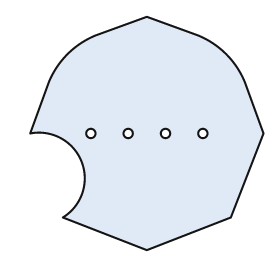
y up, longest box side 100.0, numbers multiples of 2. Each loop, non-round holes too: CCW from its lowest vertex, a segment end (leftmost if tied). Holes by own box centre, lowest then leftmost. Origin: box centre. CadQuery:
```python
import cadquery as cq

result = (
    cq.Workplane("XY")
    .moveTo(0.0, -50.0)
    .lineTo(36.0, -36.0)
    .lineTo(50.0, 0.0)
    .lineTo(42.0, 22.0)
    .threePointArc((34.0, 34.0), (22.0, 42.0))
    .lineTo(0.0, 50.0)
    .lineTo(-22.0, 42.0)
    .threePointArc((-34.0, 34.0), (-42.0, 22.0))
    .lineTo(-50.0, 0.0)
    .threePointArc((-28.0, -12.0), (-36.0, -36.0))
    .close()
    .moveTo(-24.0, 0.0)
    .circle(2.0)
    .moveTo(-8.0, 0.0)
    .circle(2.0)
    .moveTo(8.0, 0.0)
    .circle(2.0)
    .moveTo(24.0, 0.0)
    .circle(2.0)
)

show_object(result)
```